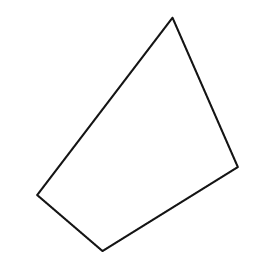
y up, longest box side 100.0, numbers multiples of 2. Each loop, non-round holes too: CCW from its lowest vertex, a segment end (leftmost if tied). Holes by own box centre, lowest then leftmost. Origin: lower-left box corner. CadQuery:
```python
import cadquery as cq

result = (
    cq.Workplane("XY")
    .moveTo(28.0, 0.0)
    .lineTo(86.0, 36.0)
    .lineTo(58.0, 100.0)
    .lineTo(0.0, 24.0)
    .close()
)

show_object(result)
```